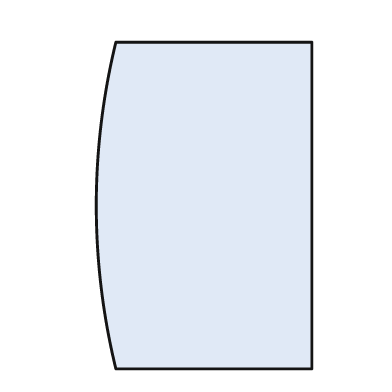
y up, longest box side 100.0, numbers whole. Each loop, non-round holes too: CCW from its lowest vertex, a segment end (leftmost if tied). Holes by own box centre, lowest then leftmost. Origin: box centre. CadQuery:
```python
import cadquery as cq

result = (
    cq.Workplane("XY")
    .moveTo(-27.0, -50.0)
    .lineTo(33.0, -50.0)
    .lineTo(33.0, 50.0)
    .lineTo(-27.0, 50.0)
    .threePointArc((-33.0, 0.0), (-27.0, -50.0))
    .close()
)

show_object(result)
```